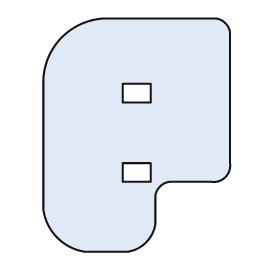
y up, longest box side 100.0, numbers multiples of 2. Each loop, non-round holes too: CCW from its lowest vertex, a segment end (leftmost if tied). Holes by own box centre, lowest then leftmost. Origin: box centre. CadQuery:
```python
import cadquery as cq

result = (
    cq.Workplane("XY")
    .moveTo(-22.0, -50.0)
    .lineTo(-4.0, -50.0)
    .threePointArc((4.0, -46.0), (8.0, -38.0))
    .lineTo(8.0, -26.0)
    .threePointArc((10.0, -22.0), (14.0, -20.0))
    .lineTo(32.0, -20.0)
    .threePointArc((38.0, -18.0), (40.0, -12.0))
    .lineTo(40.0, 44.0)
    .threePointArc((38.0, 48.0), (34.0, 50.0))
    .lineTo(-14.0, 50.0)
    .threePointArc((-32.0, 42.0), (-40.0, 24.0))
    .lineTo(-40.0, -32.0)
    .threePointArc((-34.0, -44.0), (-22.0, -50.0))
    .close()
    .moveTo(-6.0, -20.0)
    .lineTo(6.0, -20.0)
    .lineTo(6.0, -12.0)
    .lineTo(-6.0, -12.0)
    .close()
    .moveTo(-6.0, 14.0)
    .lineTo(6.0, 14.0)
    .lineTo(6.0, 22.0)
    .lineTo(-6.0, 22.0)
    .close()
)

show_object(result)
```